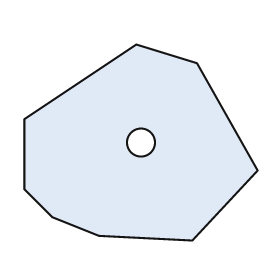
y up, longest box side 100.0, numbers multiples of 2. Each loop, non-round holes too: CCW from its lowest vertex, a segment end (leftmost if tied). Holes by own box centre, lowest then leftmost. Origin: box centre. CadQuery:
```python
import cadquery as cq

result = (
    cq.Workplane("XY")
    .moveTo(22.0, -42.0)
    .lineTo(50.0, -12.0)
    .lineTo(24.0, 34.0)
    .lineTo(-2.0, 42.0)
    .lineTo(-50.0, 10.0)
    .lineTo(-50.0, -20.0)
    .lineTo(-38.0, -32.0)
    .lineTo(-18.0, -40.0)
    .close()
    .moveTo(0.0, 0.0)
    .circle(6.0)
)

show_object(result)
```